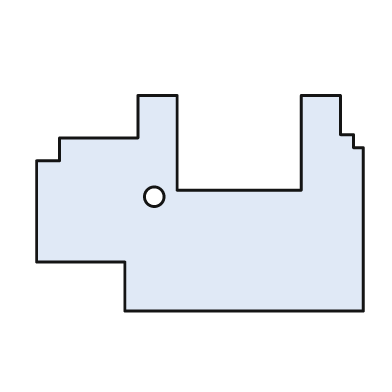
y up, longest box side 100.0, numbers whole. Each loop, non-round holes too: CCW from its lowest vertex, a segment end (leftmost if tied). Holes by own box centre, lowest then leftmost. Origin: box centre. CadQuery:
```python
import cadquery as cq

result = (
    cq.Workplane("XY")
    .moveTo(-23.0, -33.0)
    .lineTo(50.0, -33.0)
    .lineTo(50.0, 17.0)
    .lineTo(47.0, 17.0)
    .lineTo(47.0, 21.0)
    .lineTo(43.0, 21.0)
    .lineTo(43.0, 33.0)
    .lineTo(31.0, 33.0)
    .lineTo(31.0, 4.0)
    .lineTo(-7.0, 4.0)
    .lineTo(-7.0, 33.0)
    .lineTo(-19.0, 33.0)
    .lineTo(-19.0, 20.0)
    .lineTo(-43.0, 20.0)
    .lineTo(-43.0, 13.0)
    .lineTo(-50.0, 13.0)
    .lineTo(-50.0, -18.0)
    .lineTo(-23.0, -18.0)
    .close()
    .moveTo(-14.0, 2.0)
    .circle(3.0)
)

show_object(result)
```